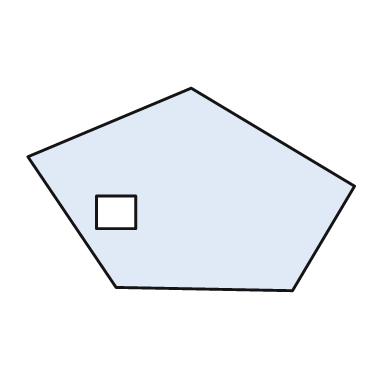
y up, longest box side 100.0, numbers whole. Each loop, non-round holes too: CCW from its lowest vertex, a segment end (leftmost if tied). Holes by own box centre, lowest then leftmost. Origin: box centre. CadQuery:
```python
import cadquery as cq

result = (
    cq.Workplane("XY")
    .moveTo(31.0, -31.0)
    .lineTo(50.0, 1.0)
    .lineTo(0.0, 31.0)
    .lineTo(-50.0, 10.0)
    .lineTo(-23.0, -30.0)
    .close()
    .moveTo(-29.0, -12.0)
    .lineTo(-17.0, -12.0)
    .lineTo(-17.0, -2.0)
    .lineTo(-29.0, -2.0)
    .close()
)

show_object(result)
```